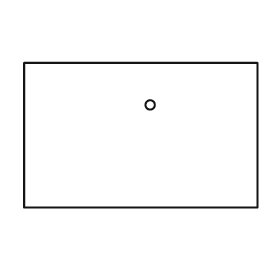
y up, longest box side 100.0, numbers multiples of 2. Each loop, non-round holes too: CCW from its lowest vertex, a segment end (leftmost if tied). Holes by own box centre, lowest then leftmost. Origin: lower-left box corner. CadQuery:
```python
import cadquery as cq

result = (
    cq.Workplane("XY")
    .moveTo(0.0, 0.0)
    .lineTo(100.0, 0.0)
    .lineTo(100.0, 62.0)
    .lineTo(0.0, 62.0)
    .close()
    .moveTo(54.0, 44.0)
    .circle(2.0)
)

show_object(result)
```